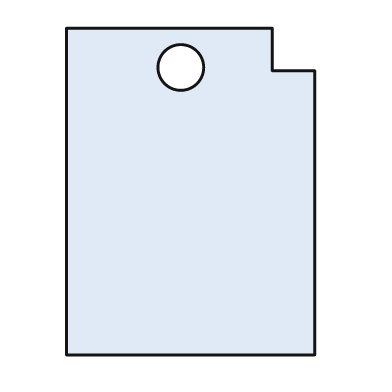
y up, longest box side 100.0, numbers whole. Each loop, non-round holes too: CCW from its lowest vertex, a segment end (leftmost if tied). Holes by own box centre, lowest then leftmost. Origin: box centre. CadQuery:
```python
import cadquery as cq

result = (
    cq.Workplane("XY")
    .moveTo(-38.0, -50.0)
    .lineTo(38.0, -50.0)
    .lineTo(38.0, 37.0)
    .lineTo(25.0, 37.0)
    .lineTo(25.0, 50.0)
    .lineTo(-38.0, 50.0)
    .close()
    .moveTo(-3.0, 38.0)
    .circle(7.0)
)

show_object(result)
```